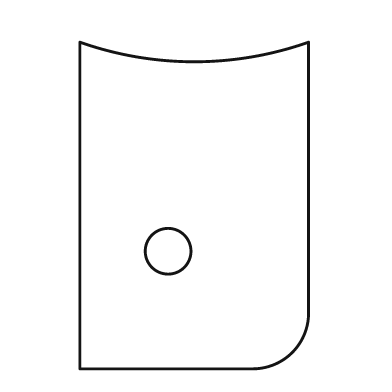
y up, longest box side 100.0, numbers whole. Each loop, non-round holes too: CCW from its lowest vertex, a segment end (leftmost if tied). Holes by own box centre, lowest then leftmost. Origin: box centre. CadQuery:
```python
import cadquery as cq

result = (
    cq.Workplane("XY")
    .moveTo(-35.0, -50.0)
    .lineTo(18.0, -50.0)
    .threePointArc((30.0, -45.0), (35.0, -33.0))
    .lineTo(35.0, 50.0)
    .threePointArc((0.0, 44.0), (-35.0, 50.0))
    .close()
    .moveTo(-8.0, -14.0)
    .circle(7.0)
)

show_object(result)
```